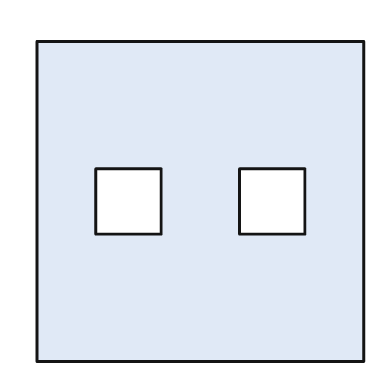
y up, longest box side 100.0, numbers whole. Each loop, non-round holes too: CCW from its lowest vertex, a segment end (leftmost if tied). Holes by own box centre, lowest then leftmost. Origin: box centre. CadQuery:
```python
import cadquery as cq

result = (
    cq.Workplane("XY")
    .moveTo(-50.0, -49.0)
    .lineTo(50.0, -49.0)
    .lineTo(50.0, 49.0)
    .lineTo(-50.0, 49.0)
    .close()
    .moveTo(-32.0, -10.0)
    .lineTo(-12.0, -10.0)
    .lineTo(-12.0, 10.0)
    .lineTo(-32.0, 10.0)
    .close()
    .moveTo(12.0, -10.0)
    .lineTo(32.0, -10.0)
    .lineTo(32.0, 10.0)
    .lineTo(12.0, 10.0)
    .close()
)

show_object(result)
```